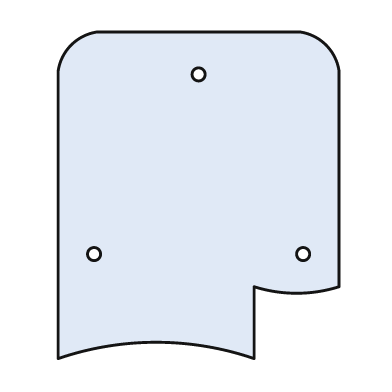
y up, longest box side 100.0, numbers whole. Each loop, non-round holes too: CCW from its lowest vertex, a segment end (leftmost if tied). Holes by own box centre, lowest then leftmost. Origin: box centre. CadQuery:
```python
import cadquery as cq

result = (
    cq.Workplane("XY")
    .moveTo(-43.0, -50.0)
    .threePointArc((-13.0, -45.0), (17.0, -50.0))
    .lineTo(17.0, -28.0)
    .threePointArc((30.0, -30.0), (43.0, -28.0))
    .lineTo(43.0, 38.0)
    .threePointArc((39.0, 46.0), (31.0, 50.0))
    .lineTo(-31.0, 50.0)
    .threePointArc((-39.0, 46.0), (-43.0, 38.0))
    .close()
    .moveTo(-32.0, -18.0)
    .circle(2.0)
    .moveTo(32.0, -18.0)
    .circle(2.0)
    .moveTo(0.0, 37.0)
    .circle(2.0)
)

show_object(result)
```